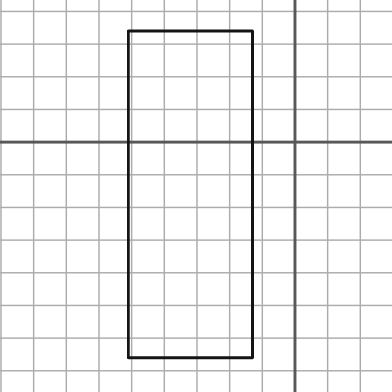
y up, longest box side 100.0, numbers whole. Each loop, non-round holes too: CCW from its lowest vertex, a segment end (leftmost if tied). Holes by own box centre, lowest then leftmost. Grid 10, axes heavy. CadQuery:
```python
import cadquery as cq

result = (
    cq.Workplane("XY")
    .moveTo(-51.0, -66.0)
    .lineTo(-13.0, -66.0)
    .lineTo(-13.0, 34.0)
    .lineTo(-51.0, 34.0)
    .close()
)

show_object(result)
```